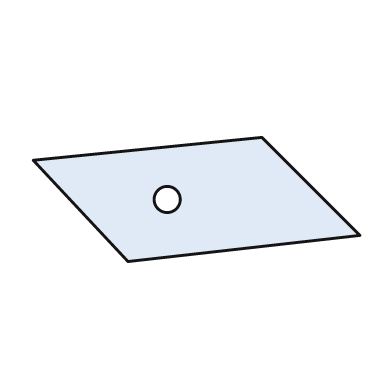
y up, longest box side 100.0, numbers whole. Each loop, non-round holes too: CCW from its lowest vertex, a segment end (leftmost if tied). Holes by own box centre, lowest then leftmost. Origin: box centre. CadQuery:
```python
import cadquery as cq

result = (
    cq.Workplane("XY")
    .moveTo(-21.0, -19.0)
    .lineTo(50.0, -11.0)
    .lineTo(20.0, 19.0)
    .lineTo(-50.0, 12.0)
    .close()
    .moveTo(-9.0, 0.0)
    .circle(4.0)
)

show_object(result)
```